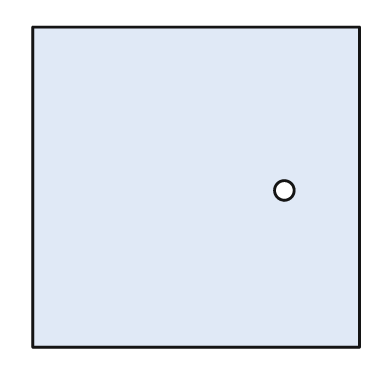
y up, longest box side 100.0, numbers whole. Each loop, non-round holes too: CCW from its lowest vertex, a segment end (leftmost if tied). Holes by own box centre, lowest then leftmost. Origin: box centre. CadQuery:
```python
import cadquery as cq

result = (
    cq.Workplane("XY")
    .moveTo(-50.0, -49.0)
    .lineTo(50.0, -49.0)
    .lineTo(50.0, 49.0)
    .lineTo(-50.0, 49.0)
    .close()
    .moveTo(27.0, -1.0)
    .circle(3.0)
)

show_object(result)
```